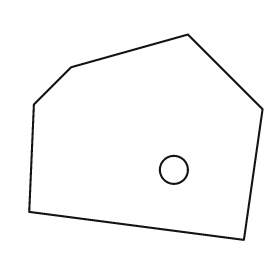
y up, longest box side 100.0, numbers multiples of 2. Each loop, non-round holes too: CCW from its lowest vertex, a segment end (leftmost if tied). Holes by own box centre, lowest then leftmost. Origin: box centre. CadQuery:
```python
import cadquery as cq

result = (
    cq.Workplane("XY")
    .moveTo(42.0, -44.0)
    .lineTo(50.0, 12.0)
    .lineTo(18.0, 44.0)
    .lineTo(-32.0, 30.0)
    .lineTo(-48.0, 14.0)
    .lineTo(-50.0, -32.0)
    .close()
    .moveTo(12.0, -14.0)
    .circle(6.0)
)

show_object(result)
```